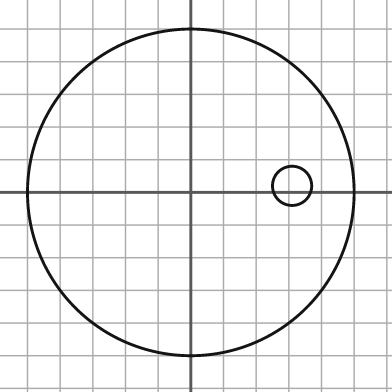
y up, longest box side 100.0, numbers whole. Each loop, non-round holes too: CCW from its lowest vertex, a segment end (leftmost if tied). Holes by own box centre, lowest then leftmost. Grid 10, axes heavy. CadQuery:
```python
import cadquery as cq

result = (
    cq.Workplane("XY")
    .moveTo(0.0, 0.0)
    .circle(50.0)
    .moveTo(31.0, 2.0)
    .circle(6.0)
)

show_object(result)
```